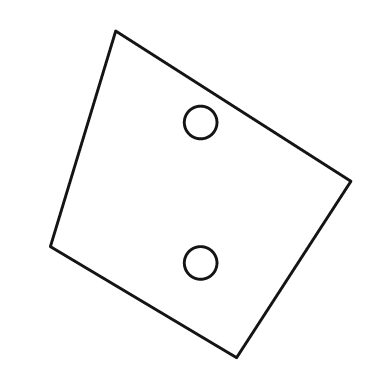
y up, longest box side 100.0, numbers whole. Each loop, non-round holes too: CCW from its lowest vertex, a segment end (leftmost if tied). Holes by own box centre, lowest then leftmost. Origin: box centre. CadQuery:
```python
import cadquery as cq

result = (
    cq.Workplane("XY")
    .moveTo(11.0, -50.0)
    .lineTo(46.0, 4.0)
    .lineTo(-26.0, 50.0)
    .lineTo(-46.0, -16.0)
    .close()
    .moveTo(0.0, -21.0)
    .circle(5.0)
    .moveTo(0.0, 22.0)
    .circle(5.0)
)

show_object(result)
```